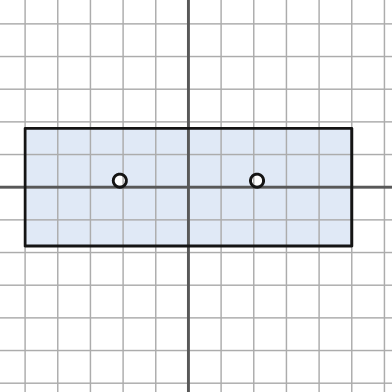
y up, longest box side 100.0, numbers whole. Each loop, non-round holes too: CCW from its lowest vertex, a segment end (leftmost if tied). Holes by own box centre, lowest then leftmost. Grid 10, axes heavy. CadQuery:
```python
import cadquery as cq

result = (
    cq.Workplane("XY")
    .moveTo(-50.0, -18.0)
    .lineTo(50.0, -18.0)
    .lineTo(50.0, 18.0)
    .lineTo(-50.0, 18.0)
    .close()
    .moveTo(-21.0, 2.0)
    .circle(2.0)
    .moveTo(21.0, 2.0)
    .circle(2.0)
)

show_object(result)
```